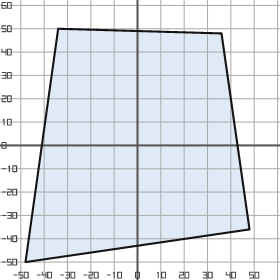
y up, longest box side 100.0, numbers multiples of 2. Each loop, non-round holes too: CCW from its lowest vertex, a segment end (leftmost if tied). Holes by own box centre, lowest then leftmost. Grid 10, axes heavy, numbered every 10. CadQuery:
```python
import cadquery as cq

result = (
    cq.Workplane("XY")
    .moveTo(-48.0, -50.0)
    .lineTo(48.0, -36.0)
    .lineTo(36.0, 48.0)
    .lineTo(-34.0, 50.0)
    .close()
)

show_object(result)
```